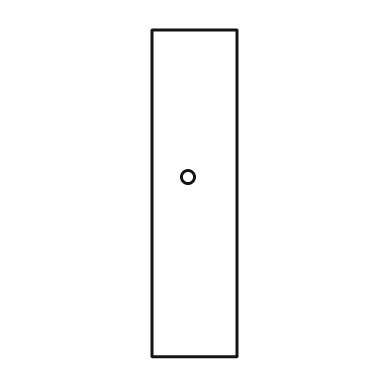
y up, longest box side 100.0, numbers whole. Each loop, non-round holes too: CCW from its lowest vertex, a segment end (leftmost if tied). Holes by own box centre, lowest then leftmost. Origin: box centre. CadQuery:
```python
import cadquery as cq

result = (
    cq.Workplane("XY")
    .moveTo(-13.0, -50.0)
    .lineTo(13.0, -50.0)
    .lineTo(13.0, 50.0)
    .lineTo(-13.0, 50.0)
    .close()
    .moveTo(-2.0, 5.0)
    .circle(2.0)
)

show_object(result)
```